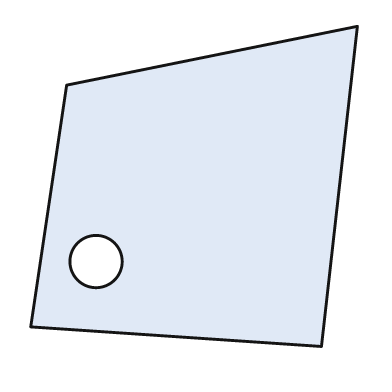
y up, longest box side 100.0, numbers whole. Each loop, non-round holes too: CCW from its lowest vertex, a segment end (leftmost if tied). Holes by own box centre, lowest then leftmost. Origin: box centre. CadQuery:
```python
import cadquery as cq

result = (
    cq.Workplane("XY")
    .moveTo(39.0, -49.0)
    .lineTo(50.0, 49.0)
    .lineTo(-39.0, 31.0)
    .lineTo(-50.0, -43.0)
    .close()
    .moveTo(-30.0, -23.0)
    .circle(8.0)
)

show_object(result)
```